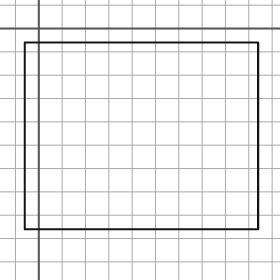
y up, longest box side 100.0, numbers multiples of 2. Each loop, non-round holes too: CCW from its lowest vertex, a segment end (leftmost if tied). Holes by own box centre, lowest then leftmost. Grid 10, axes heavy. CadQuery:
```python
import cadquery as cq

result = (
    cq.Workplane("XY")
    .moveTo(-6.0, -86.0)
    .lineTo(94.0, -86.0)
    .lineTo(94.0, -6.0)
    .lineTo(-6.0, -6.0)
    .close()
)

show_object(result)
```